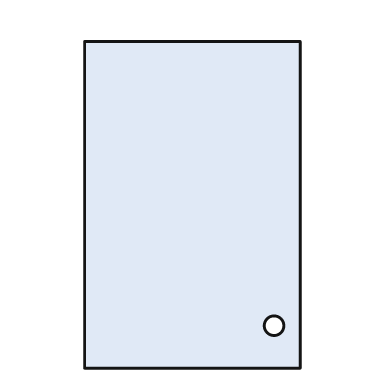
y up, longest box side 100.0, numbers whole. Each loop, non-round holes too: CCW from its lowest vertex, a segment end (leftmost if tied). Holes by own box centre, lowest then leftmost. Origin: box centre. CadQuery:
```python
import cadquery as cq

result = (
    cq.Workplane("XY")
    .moveTo(-33.0, -50.0)
    .lineTo(33.0, -50.0)
    .lineTo(33.0, 50.0)
    .lineTo(-33.0, 50.0)
    .close()
    .moveTo(25.0, -37.0)
    .circle(3.0)
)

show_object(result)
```